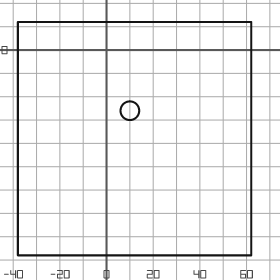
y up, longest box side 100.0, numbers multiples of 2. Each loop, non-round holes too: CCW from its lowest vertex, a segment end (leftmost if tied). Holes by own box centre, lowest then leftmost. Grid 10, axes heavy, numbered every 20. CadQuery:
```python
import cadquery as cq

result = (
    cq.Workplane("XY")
    .moveTo(-38.0, -88.0)
    .lineTo(62.0, -88.0)
    .lineTo(62.0, 12.0)
    .lineTo(-38.0, 12.0)
    .close()
    .moveTo(10.0, -26.0)
    .circle(4.0)
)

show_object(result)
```